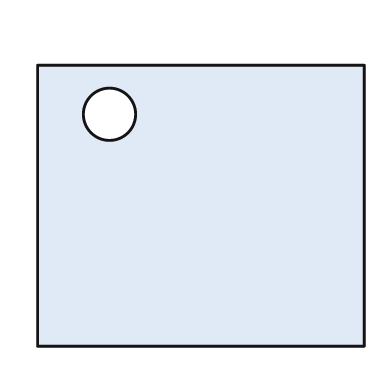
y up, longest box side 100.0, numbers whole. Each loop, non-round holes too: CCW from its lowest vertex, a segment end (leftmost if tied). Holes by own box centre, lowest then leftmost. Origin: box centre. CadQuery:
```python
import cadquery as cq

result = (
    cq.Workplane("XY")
    .moveTo(-50.0, -43.0)
    .lineTo(50.0, -43.0)
    .lineTo(50.0, 43.0)
    .lineTo(-50.0, 43.0)
    .close()
    .moveTo(-28.0, 28.0)
    .circle(8.0)
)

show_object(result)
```